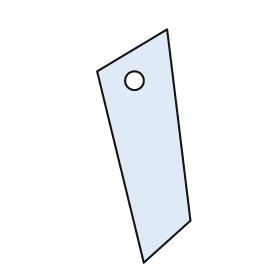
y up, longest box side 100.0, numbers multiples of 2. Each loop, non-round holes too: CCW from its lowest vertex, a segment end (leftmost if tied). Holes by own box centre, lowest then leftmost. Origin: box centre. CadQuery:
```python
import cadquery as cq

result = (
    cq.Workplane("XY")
    .moveTo(0.0, -50.0)
    .lineTo(20.0, -32.0)
    .lineTo(10.0, 50.0)
    .lineTo(-20.0, 32.0)
    .close()
    .moveTo(-4.0, 28.0)
    .circle(4.0)
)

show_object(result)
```